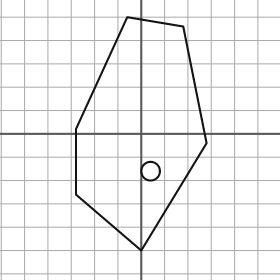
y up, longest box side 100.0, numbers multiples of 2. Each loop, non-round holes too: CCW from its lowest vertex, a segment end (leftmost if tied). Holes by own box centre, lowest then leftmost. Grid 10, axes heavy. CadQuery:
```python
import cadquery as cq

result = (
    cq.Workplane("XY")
    .moveTo(0.0, -50.0)
    .lineTo(28.0, -4.0)
    .lineTo(18.0, 46.0)
    .lineTo(-6.0, 50.0)
    .lineTo(-28.0, 2.0)
    .lineTo(-28.0, -26.0)
    .close()
    .moveTo(4.0, -16.0)
    .circle(4.0)
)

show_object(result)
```